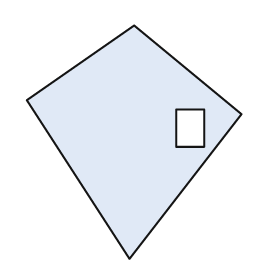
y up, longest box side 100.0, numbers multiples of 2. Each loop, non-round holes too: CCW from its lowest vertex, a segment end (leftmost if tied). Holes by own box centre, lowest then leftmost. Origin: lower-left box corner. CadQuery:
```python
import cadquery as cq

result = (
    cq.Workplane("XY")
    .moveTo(44.0, 0.0)
    .lineTo(92.0, 62.0)
    .lineTo(46.0, 100.0)
    .lineTo(0.0, 68.0)
    .close()
    .moveTo(64.0, 48.0)
    .lineTo(76.0, 48.0)
    .lineTo(76.0, 64.0)
    .lineTo(64.0, 64.0)
    .close()
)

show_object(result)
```